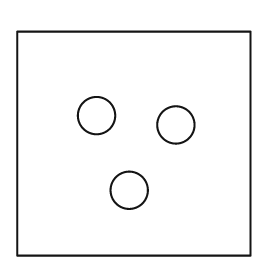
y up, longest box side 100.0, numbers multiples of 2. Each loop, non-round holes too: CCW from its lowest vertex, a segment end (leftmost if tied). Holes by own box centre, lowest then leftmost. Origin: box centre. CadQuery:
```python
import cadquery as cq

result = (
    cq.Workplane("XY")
    .moveTo(-50.0, -48.0)
    .lineTo(50.0, -48.0)
    .lineTo(50.0, 48.0)
    .lineTo(-50.0, 48.0)
    .close()
    .moveTo(-2.0, -20.0)
    .circle(8.0)
    .moveTo(18.0, 8.0)
    .circle(8.0)
    .moveTo(-16.0, 12.0)
    .circle(8.0)
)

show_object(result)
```